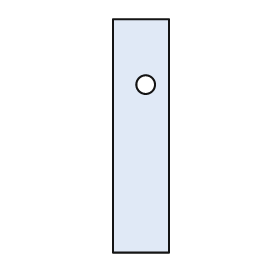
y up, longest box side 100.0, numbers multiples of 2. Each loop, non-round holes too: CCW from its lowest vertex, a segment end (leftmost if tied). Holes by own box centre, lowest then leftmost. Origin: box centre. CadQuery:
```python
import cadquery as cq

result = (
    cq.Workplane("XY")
    .moveTo(-12.0, -50.0)
    .lineTo(12.0, -50.0)
    .lineTo(12.0, 50.0)
    .lineTo(-12.0, 50.0)
    .close()
    .moveTo(2.0, 22.0)
    .circle(4.0)
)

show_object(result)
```